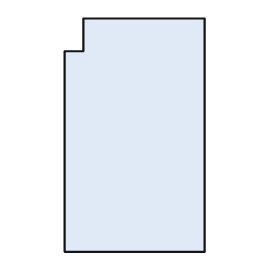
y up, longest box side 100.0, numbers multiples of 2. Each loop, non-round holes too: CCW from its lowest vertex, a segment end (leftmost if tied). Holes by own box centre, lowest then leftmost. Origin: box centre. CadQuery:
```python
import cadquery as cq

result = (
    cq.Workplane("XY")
    .moveTo(-30.0, -50.0)
    .lineTo(30.0, -50.0)
    .lineTo(30.0, 50.0)
    .lineTo(-22.0, 50.0)
    .lineTo(-22.0, 36.0)
    .lineTo(-30.0, 36.0)
    .close()
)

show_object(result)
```